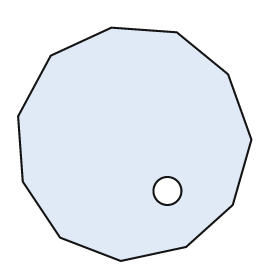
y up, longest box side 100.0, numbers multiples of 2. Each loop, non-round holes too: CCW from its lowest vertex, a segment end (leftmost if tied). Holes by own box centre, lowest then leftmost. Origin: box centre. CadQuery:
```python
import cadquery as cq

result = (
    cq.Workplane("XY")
    .moveTo(-6.0, -50.0)
    .lineTo(22.0, -44.0)
    .lineTo(42.0, -26.0)
    .lineTo(50.0, 2.0)
    .lineTo(40.0, 30.0)
    .lineTo(18.0, 48.0)
    .lineTo(-10.0, 50.0)
    .lineTo(-36.0, 38.0)
    .lineTo(-50.0, 12.0)
    .lineTo(-48.0, -16.0)
    .lineTo(-32.0, -40.0)
    .close()
    .moveTo(14.0, -20.0)
    .circle(6.0)
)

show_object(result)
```